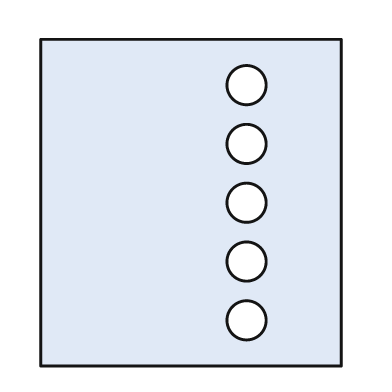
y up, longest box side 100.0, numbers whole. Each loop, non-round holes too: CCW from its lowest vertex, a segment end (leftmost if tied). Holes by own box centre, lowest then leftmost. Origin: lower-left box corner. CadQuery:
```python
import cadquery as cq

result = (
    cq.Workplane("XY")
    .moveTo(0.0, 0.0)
    .lineTo(92.0, 0.0)
    .lineTo(92.0, 100.0)
    .lineTo(0.0, 100.0)
    .close()
    .moveTo(63.0, 14.0)
    .circle(6.0)
    .moveTo(63.0, 32.0)
    .circle(6.0)
    .moveTo(63.0, 50.0)
    .circle(6.0)
    .moveTo(63.0, 68.0)
    .circle(6.0)
    .moveTo(63.0, 86.0)
    .circle(6.0)
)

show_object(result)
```